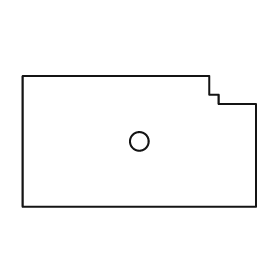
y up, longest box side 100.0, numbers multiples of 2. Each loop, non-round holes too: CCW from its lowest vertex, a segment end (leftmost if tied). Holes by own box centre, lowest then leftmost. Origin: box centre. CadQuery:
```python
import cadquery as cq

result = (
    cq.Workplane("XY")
    .moveTo(-50.0, -28.0)
    .lineTo(50.0, -28.0)
    .lineTo(50.0, 16.0)
    .lineTo(34.0, 16.0)
    .lineTo(34.0, 20.0)
    .lineTo(30.0, 20.0)
    .lineTo(30.0, 28.0)
    .lineTo(-50.0, 28.0)
    .close()
    .moveTo(0.0, 0.0)
    .circle(4.0)
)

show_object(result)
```